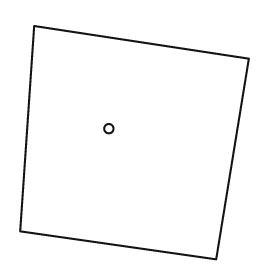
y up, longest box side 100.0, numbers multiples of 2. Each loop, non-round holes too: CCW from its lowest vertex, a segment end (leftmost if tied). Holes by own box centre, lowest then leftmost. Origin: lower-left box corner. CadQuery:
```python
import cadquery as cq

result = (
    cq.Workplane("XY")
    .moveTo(84.0, 0.0)
    .lineTo(98.0, 86.0)
    .lineTo(6.0, 100.0)
    .lineTo(0.0, 12.0)
    .close()
    .moveTo(38.0, 56.0)
    .circle(2.0)
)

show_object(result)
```